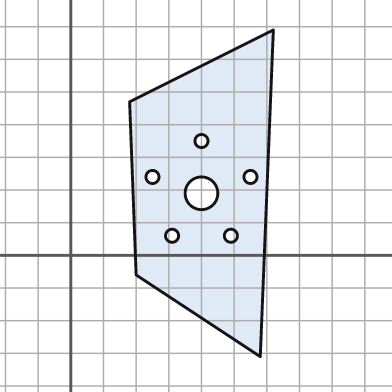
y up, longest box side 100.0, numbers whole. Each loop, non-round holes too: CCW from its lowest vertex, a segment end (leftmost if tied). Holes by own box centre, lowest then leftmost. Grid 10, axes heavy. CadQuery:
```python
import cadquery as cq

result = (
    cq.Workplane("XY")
    .moveTo(58.0, -31.0)
    .lineTo(62.0, 69.0)
    .lineTo(18.0, 47.0)
    .lineTo(20.0, -6.0)
    .close()
    .moveTo(31.0, 6.0)
    .circle(2.0)
    .moveTo(49.0, 6.0)
    .circle(2.0)
    .moveTo(40.0, 19.0)
    .circle(5.0)
    .moveTo(25.0, 24.0)
    .circle(2.0)
    .moveTo(55.0, 24.0)
    .circle(2.0)
    .moveTo(40.0, 35.0)
    .circle(2.0)
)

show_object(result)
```